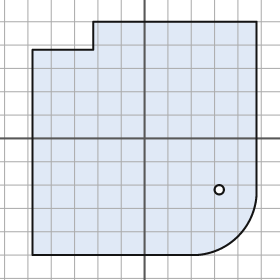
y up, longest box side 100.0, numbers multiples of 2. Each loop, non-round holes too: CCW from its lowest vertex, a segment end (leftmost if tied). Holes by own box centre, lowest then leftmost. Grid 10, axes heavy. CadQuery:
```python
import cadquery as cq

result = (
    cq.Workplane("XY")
    .moveTo(-48.0, -50.0)
    .lineTo(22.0, -50.0)
    .threePointArc((40.0, -42.0), (48.0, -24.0))
    .lineTo(48.0, 50.0)
    .lineTo(-22.0, 50.0)
    .lineTo(-22.0, 38.0)
    .lineTo(-48.0, 38.0)
    .close()
    .moveTo(32.0, -22.0)
    .circle(2.0)
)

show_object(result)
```